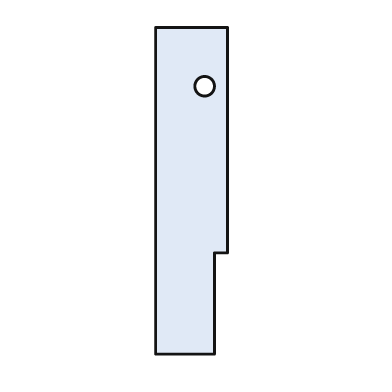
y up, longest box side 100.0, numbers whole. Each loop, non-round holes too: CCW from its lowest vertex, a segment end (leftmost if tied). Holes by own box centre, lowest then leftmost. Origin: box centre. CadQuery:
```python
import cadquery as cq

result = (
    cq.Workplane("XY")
    .moveTo(-11.0, -50.0)
    .lineTo(7.0, -50.0)
    .lineTo(7.0, -19.0)
    .lineTo(11.0, -19.0)
    .lineTo(11.0, 50.0)
    .lineTo(-11.0, 50.0)
    .close()
    .moveTo(4.0, 32.0)
    .circle(3.0)
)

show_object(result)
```